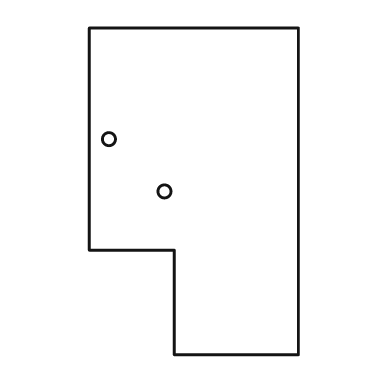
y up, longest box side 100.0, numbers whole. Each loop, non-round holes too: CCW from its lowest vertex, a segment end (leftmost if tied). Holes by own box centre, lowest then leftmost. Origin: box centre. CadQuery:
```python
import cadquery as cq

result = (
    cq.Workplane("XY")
    .moveTo(-6.0, -50.0)
    .lineTo(32.0, -50.0)
    .lineTo(32.0, 50.0)
    .lineTo(-32.0, 50.0)
    .lineTo(-32.0, -18.0)
    .lineTo(-6.0, -18.0)
    .close()
    .moveTo(-9.0, 0.0)
    .circle(2.0)
    .moveTo(-26.0, 16.0)
    .circle(2.0)
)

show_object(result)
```